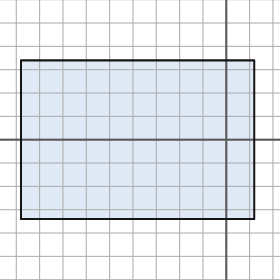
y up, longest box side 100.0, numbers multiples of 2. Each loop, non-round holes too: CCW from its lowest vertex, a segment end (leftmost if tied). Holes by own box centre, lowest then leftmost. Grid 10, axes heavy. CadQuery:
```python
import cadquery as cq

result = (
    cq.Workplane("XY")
    .moveTo(-88.0, -34.0)
    .lineTo(12.0, -34.0)
    .lineTo(12.0, 34.0)
    .lineTo(-88.0, 34.0)
    .close()
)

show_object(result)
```